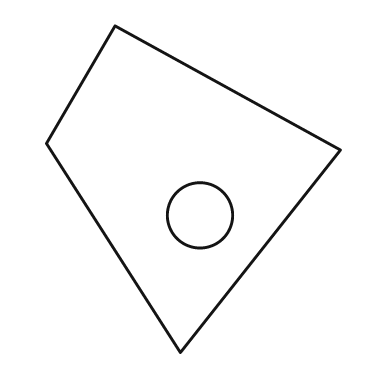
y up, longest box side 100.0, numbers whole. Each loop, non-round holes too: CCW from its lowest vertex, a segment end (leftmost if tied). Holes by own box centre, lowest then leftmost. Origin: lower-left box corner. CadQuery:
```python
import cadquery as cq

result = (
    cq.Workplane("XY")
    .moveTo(41.0, 0.0)
    .lineTo(90.0, 62.0)
    .lineTo(21.0, 100.0)
    .lineTo(0.0, 64.0)
    .close()
    .moveTo(47.0, 42.0)
    .circle(10.0)
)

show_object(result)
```